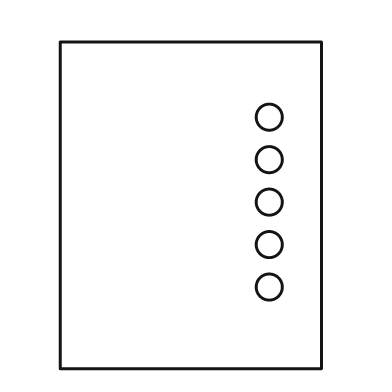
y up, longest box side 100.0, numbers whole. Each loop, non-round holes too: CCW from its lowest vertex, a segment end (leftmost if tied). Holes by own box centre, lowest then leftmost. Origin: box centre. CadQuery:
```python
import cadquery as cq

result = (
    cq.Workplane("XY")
    .moveTo(-40.0, -50.0)
    .lineTo(40.0, -50.0)
    .lineTo(40.0, 50.0)
    .lineTo(-40.0, 50.0)
    .close()
    .moveTo(24.0, -25.0)
    .circle(4.0)
    .moveTo(24.0, -12.0)
    .circle(4.0)
    .moveTo(24.0, 1.0)
    .circle(4.0)
    .moveTo(24.0, 14.0)
    .circle(4.0)
    .moveTo(24.0, 27.0)
    .circle(4.0)
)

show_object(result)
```